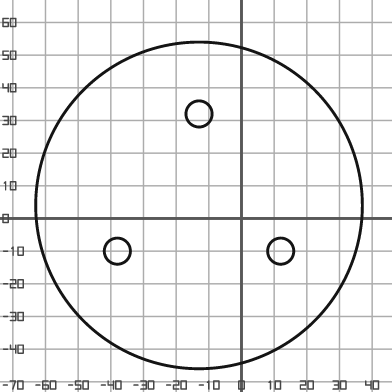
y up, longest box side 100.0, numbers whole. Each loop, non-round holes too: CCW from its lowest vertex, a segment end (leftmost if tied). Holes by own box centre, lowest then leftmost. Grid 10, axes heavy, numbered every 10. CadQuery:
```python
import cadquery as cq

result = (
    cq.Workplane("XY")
    .moveTo(-13.0, 4.0)
    .circle(50.0)
    .moveTo(-38.0, -10.0)
    .circle(4.0)
    .moveTo(12.0, -10.0)
    .circle(4.0)
    .moveTo(-13.0, 32.0)
    .circle(4.0)
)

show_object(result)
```